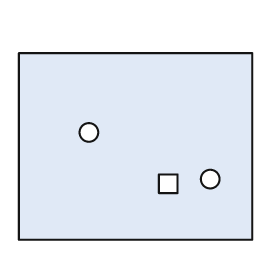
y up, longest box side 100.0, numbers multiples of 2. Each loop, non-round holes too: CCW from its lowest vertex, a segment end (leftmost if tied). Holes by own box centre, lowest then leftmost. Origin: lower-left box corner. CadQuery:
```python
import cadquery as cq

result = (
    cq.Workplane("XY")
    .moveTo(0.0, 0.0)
    .lineTo(100.0, 0.0)
    .lineTo(100.0, 80.0)
    .lineTo(0.0, 80.0)
    .close()
    .moveTo(60.0, 20.0)
    .lineTo(68.0, 20.0)
    .lineTo(68.0, 28.0)
    .lineTo(60.0, 28.0)
    .close()
    .moveTo(82.0, 26.0)
    .circle(4.0)
    .moveTo(30.0, 46.0)
    .circle(4.0)
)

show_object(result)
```